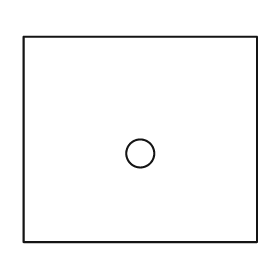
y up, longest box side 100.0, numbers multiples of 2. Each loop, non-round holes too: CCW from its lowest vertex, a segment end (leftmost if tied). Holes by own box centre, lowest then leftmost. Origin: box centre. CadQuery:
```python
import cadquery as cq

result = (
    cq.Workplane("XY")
    .moveTo(-50.0, -44.0)
    .lineTo(50.0, -44.0)
    .lineTo(50.0, 44.0)
    .lineTo(-50.0, 44.0)
    .close()
    .moveTo(0.0, -6.0)
    .circle(6.0)
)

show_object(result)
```